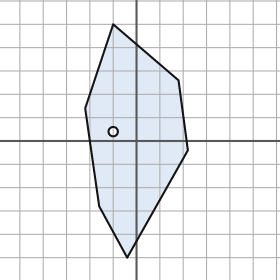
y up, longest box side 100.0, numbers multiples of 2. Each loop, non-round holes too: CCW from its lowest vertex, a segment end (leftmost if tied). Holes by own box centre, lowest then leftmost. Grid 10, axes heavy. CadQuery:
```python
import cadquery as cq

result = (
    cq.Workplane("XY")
    .moveTo(-4.0, -50.0)
    .lineTo(22.0, -4.0)
    .lineTo(18.0, 26.0)
    .lineTo(-10.0, 50.0)
    .lineTo(-22.0, 14.0)
    .lineTo(-16.0, -28.0)
    .close()
    .moveTo(-10.0, 4.0)
    .circle(2.0)
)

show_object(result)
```